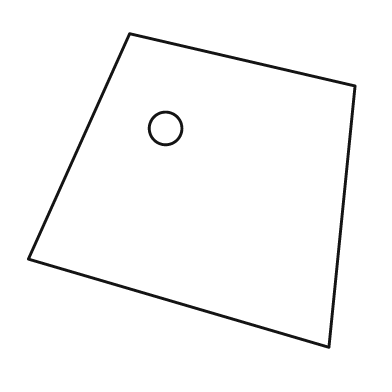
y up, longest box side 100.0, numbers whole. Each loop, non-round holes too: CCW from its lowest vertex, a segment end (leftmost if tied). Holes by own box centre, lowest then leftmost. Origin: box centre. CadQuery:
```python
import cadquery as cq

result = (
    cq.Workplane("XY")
    .moveTo(42.0, -48.0)
    .lineTo(50.0, 32.0)
    .lineTo(-19.0, 48.0)
    .lineTo(-50.0, -21.0)
    .close()
    .moveTo(-8.0, 19.0)
    .circle(5.0)
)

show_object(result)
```